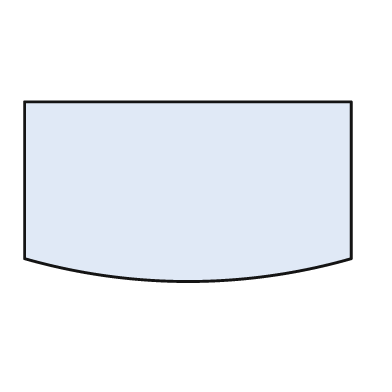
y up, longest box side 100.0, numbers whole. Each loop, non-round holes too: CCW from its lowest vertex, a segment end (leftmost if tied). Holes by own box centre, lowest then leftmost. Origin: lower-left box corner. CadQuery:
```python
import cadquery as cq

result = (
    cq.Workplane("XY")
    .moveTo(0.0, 7.0)
    .threePointArc((50.0, 0.0), (100.0, 7.0))
    .lineTo(100.0, 55.0)
    .lineTo(0.0, 55.0)
    .close()
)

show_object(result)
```